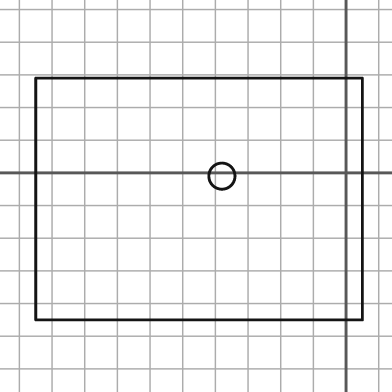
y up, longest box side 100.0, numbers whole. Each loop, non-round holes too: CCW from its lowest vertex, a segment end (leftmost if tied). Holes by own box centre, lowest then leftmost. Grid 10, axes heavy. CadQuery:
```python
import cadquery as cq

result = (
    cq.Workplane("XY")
    .moveTo(-95.0, -45.0)
    .lineTo(5.0, -45.0)
    .lineTo(5.0, 29.0)
    .lineTo(-95.0, 29.0)
    .close()
    .moveTo(-38.0, -1.0)
    .circle(4.0)
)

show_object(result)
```